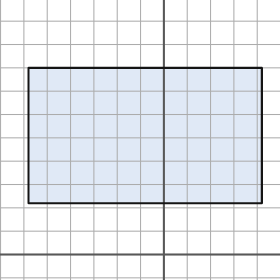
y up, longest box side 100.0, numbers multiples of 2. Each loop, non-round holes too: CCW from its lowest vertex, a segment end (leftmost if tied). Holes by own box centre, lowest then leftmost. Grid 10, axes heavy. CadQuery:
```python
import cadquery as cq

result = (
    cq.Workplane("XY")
    .moveTo(-58.0, 22.0)
    .lineTo(42.0, 22.0)
    .lineTo(42.0, 80.0)
    .lineTo(-58.0, 80.0)
    .close()
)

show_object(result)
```